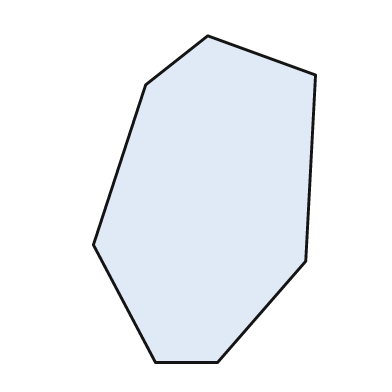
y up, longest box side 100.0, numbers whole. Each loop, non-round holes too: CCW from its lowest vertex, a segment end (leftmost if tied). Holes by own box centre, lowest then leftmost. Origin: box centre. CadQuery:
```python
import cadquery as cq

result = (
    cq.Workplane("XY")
    .moveTo(-15.0, -50.0)
    .lineTo(4.0, -50.0)
    .lineTo(31.0, -19.0)
    .lineTo(34.0, 38.0)
    .lineTo(1.0, 50.0)
    .lineTo(-18.0, 35.0)
    .lineTo(-34.0, -14.0)
    .close()
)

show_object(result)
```